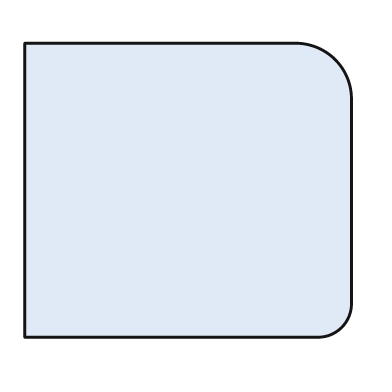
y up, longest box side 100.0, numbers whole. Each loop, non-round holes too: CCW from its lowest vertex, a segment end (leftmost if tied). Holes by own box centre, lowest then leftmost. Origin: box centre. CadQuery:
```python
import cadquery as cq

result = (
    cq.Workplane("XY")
    .moveTo(-50.0, -45.0)
    .lineTo(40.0, -45.0)
    .threePointArc((47.0, -42.0), (50.0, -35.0))
    .lineTo(50.0, 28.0)
    .threePointArc((45.0, 40.0), (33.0, 45.0))
    .lineTo(-50.0, 45.0)
    .close()
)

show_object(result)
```